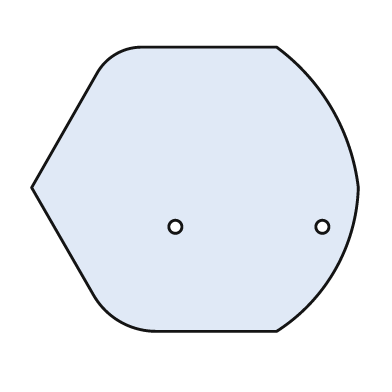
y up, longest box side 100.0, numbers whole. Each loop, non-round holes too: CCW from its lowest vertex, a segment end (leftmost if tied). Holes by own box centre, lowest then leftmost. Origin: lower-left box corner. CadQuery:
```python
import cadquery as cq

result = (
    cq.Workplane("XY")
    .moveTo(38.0, 0.0)
    .lineTo(75.0, 0.0)
    .threePointArc((93.0, 19.0), (100.0, 44.0))
    .threePointArc((92.0, 68.0), (75.0, 87.0))
    .lineTo(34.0, 87.0)
    .threePointArc((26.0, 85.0), (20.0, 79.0))
    .lineTo(0.0, 44.0)
    .lineTo(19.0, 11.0)
    .threePointArc((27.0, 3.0), (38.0, 0.0))
    .close()
    .moveTo(44.0, 32.0)
    .circle(2.0)
    .moveTo(89.0, 32.0)
    .circle(2.0)
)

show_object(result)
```